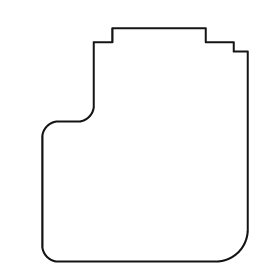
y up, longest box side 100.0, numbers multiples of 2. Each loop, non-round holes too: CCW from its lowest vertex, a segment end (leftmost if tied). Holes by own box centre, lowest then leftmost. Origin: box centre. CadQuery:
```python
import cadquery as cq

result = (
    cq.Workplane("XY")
    .moveTo(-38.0, -50.0)
    .lineTo(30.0, -50.0)
    .threePointArc((40.0, -46.0), (44.0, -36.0))
    .lineTo(44.0, 40.0)
    .lineTo(38.0, 40.0)
    .lineTo(38.0, 44.0)
    .lineTo(26.0, 44.0)
    .lineTo(26.0, 50.0)
    .lineTo(-14.0, 50.0)
    .lineTo(-14.0, 44.0)
    .lineTo(-22.0, 44.0)
    .lineTo(-22.0, 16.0)
    .threePointArc((-24.0, 12.0), (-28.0, 10.0))
    .lineTo(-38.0, 10.0)
    .threePointArc((-42.0, 8.0), (-44.0, 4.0))
    .lineTo(-44.0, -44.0)
    .threePointArc((-42.0, -48.0), (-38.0, -50.0))
    .close()
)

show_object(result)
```